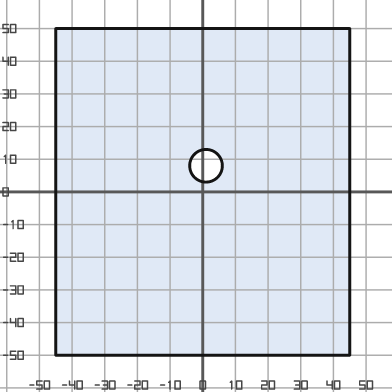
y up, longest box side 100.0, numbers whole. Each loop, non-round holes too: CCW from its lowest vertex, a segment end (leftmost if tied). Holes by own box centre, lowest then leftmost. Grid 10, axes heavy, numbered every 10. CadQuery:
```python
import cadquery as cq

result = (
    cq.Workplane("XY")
    .moveTo(-45.0, -50.0)
    .lineTo(45.0, -50.0)
    .lineTo(45.0, 50.0)
    .lineTo(-45.0, 50.0)
    .close()
    .moveTo(1.0, 8.0)
    .circle(5.0)
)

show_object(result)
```